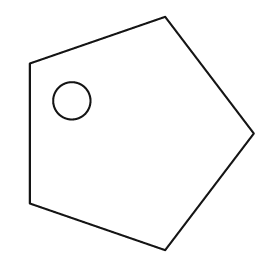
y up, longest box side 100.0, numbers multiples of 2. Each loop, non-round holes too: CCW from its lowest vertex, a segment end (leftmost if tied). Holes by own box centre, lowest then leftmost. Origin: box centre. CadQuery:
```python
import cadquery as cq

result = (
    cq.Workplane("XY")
    .moveTo(10.0, -50.0)
    .lineTo(48.0, 0.0)
    .lineTo(10.0, 50.0)
    .lineTo(-48.0, 30.0)
    .lineTo(-48.0, -30.0)
    .close()
    .moveTo(-30.0, 14.0)
    .circle(8.0)
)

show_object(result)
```